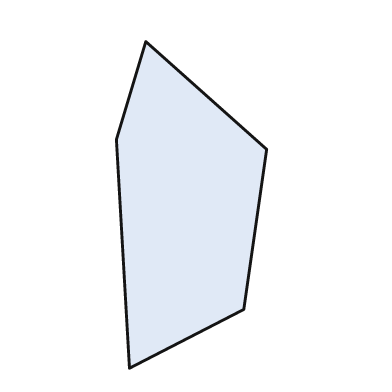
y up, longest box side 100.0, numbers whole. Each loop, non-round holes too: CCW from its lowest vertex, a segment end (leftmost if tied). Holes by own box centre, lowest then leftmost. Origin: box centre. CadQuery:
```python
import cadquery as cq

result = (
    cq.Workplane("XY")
    .moveTo(-19.0, -50.0)
    .lineTo(16.0, -32.0)
    .lineTo(23.0, 17.0)
    .lineTo(-14.0, 50.0)
    .lineTo(-23.0, 20.0)
    .close()
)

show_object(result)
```